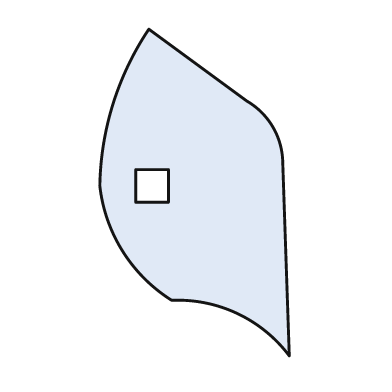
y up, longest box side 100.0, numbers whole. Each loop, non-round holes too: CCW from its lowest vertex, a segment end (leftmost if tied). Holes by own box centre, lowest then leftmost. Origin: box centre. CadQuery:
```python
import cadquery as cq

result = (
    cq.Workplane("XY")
    .moveTo(29.0, -50.0)
    .lineTo(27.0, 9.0)
    .threePointArc((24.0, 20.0), (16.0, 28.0))
    .lineTo(-14.0, 50.0)
    .threePointArc((-25.0, 27.0), (-29.0, 2.0))
    .threePointArc((-22.0, -18.0), (-7.0, -33.0))
    .threePointArc((13.0, -37.0), (29.0, -50.0))
    .close()
    .moveTo(-18.0, -3.0)
    .lineTo(-8.0, -3.0)
    .lineTo(-8.0, 7.0)
    .lineTo(-18.0, 7.0)
    .close()
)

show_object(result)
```